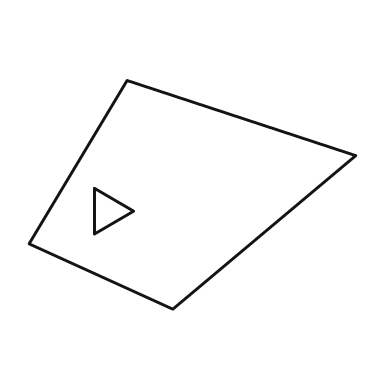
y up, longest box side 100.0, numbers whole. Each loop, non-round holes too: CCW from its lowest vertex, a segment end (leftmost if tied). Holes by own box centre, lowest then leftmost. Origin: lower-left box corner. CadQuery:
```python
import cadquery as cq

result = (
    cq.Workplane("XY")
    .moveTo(44.0, 0.0)
    .lineTo(100.0, 47.0)
    .lineTo(30.0, 70.0)
    .lineTo(0.0, 20.0)
    .close()
    .moveTo(20.0, 23.0)
    .lineTo(32.0, 30.0)
    .lineTo(20.0, 37.0)
    .close()
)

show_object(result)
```